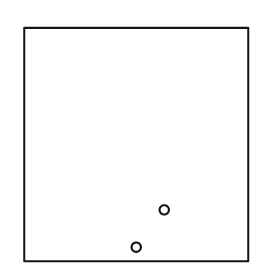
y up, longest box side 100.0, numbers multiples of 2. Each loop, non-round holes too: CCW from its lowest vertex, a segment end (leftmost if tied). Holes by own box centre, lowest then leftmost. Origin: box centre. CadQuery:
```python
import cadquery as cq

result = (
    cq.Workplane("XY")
    .moveTo(-48.0, -50.0)
    .lineTo(48.0, -50.0)
    .lineTo(48.0, 50.0)
    .lineTo(-48.0, 50.0)
    .close()
    .moveTo(0.0, -44.0)
    .circle(2.0)
    .moveTo(12.0, -28.0)
    .circle(2.0)
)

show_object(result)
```